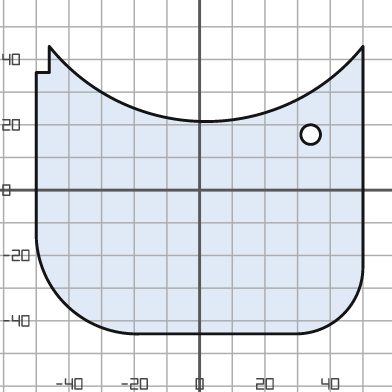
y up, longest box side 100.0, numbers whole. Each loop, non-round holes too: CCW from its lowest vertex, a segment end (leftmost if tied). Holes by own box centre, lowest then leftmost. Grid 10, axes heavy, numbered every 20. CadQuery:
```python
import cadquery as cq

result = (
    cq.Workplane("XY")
    .moveTo(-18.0, -44.0)
    .lineTo(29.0, -44.0)
    .threePointArc((44.0, -38.0), (50.0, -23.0))
    .lineTo(50.0, 44.0)
    .threePointArc((2.0, 21.0), (-46.0, 44.0))
    .lineTo(-46.0, 36.0)
    .lineTo(-50.0, 36.0)
    .lineTo(-50.0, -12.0)
    .threePointArc((-41.0, -35.0), (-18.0, -44.0))
    .close()
    .moveTo(34.0, 17.0)
    .circle(3.0)
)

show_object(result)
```